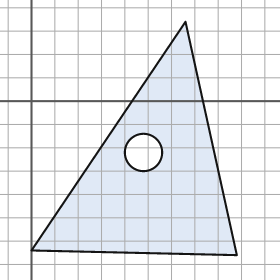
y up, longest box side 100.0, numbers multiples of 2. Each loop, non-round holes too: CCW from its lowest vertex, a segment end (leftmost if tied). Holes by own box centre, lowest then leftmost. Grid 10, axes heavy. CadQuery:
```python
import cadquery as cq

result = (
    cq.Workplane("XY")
    .moveTo(88.0, -66.0)
    .lineTo(66.0, 34.0)
    .lineTo(0.0, -64.0)
    .close()
    .moveTo(48.0, -22.0)
    .circle(8.0)
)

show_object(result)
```